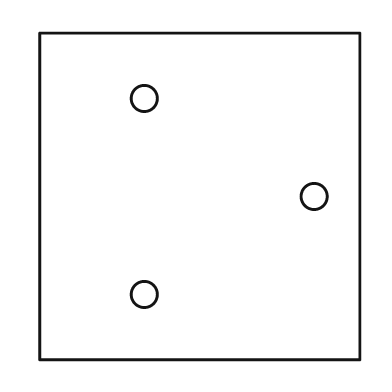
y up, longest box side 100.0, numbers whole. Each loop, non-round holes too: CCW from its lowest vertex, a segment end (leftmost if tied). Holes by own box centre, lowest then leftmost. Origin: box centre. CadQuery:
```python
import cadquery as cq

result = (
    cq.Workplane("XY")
    .moveTo(-49.0, -50.0)
    .lineTo(49.0, -50.0)
    .lineTo(49.0, 50.0)
    .lineTo(-49.0, 50.0)
    .close()
    .moveTo(-17.0, -30.0)
    .circle(4.0)
    .moveTo(35.0, 0.0)
    .circle(4.0)
    .moveTo(-17.0, 30.0)
    .circle(4.0)
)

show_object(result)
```